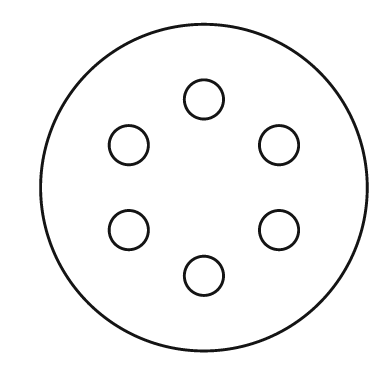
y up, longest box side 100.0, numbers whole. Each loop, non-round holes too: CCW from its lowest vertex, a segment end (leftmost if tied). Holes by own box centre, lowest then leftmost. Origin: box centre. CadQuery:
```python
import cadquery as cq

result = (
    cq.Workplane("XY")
    .moveTo(0.0, 0.0)
    .circle(50.0)
    .moveTo(0.0, -27.0)
    .circle(6.0)
    .moveTo(-23.0, -13.0)
    .circle(6.0)
    .moveTo(23.0, -13.0)
    .circle(6.0)
    .moveTo(-23.0, 13.0)
    .circle(6.0)
    .moveTo(23.0, 13.0)
    .circle(6.0)
    .moveTo(0.0, 27.0)
    .circle(6.0)
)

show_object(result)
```